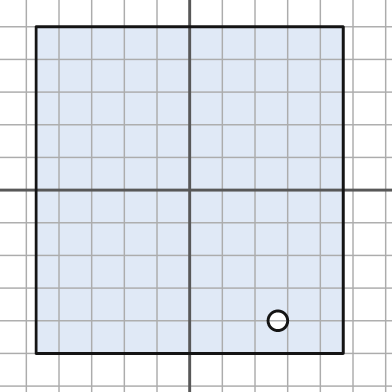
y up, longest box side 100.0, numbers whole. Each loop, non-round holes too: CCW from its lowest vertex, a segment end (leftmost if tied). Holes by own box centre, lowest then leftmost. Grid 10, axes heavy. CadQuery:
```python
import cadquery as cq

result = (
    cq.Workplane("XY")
    .moveTo(-47.0, -50.0)
    .lineTo(47.0, -50.0)
    .lineTo(47.0, 50.0)
    .lineTo(-47.0, 50.0)
    .close()
    .moveTo(27.0, -40.0)
    .circle(3.0)
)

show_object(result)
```